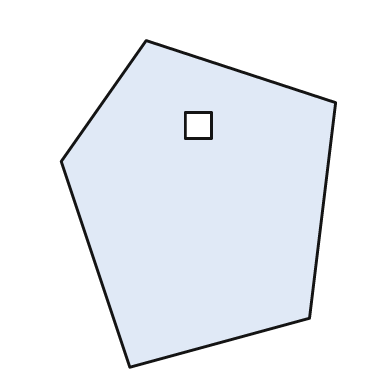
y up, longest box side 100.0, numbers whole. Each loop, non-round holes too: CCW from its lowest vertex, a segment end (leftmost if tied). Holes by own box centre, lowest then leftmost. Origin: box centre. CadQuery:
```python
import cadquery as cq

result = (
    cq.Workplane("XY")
    .moveTo(-21.0, -50.0)
    .lineTo(34.0, -35.0)
    .lineTo(42.0, 31.0)
    .lineTo(-16.0, 50.0)
    .lineTo(-42.0, 13.0)
    .close()
    .moveTo(-4.0, 20.0)
    .lineTo(4.0, 20.0)
    .lineTo(4.0, 28.0)
    .lineTo(-4.0, 28.0)
    .close()
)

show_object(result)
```